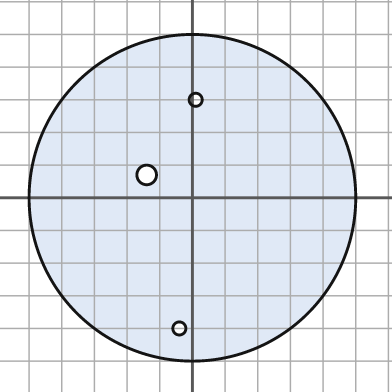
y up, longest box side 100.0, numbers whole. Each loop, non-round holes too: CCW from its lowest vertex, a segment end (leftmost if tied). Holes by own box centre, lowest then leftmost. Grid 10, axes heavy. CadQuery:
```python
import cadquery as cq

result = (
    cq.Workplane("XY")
    .moveTo(0.0, 0.0)
    .circle(50.0)
    .moveTo(-4.0, -40.0)
    .circle(2.0)
    .moveTo(-14.0, 7.0)
    .circle(3.0)
    .moveTo(1.0, 30.0)
    .circle(2.0)
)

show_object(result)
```